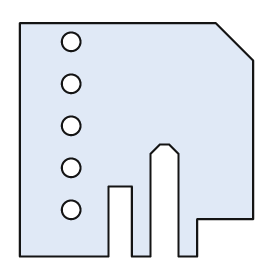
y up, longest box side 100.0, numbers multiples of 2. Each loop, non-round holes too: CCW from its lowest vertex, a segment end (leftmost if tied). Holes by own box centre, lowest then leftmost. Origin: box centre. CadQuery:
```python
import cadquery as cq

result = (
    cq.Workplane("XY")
    .moveTo(-50.0, -50.0)
    .lineTo(-12.0, -50.0)
    .lineTo(-12.0, -20.0)
    .lineTo(-2.0, -20.0)
    .lineTo(-2.0, -50.0)
    .lineTo(6.0, -50.0)
    .lineTo(6.0, -6.0)
    .lineTo(10.0, -2.0)
    .lineTo(14.0, -2.0)
    .lineTo(18.0, -6.0)
    .lineTo(18.0, -50.0)
    .lineTo(26.0, -50.0)
    .lineTo(26.0, -34.0)
    .lineTo(50.0, -34.0)
    .lineTo(50.0, 34.0)
    .lineTo(34.0, 50.0)
    .lineTo(-50.0, 50.0)
    .close()
    .moveTo(-28.0, -30.0)
    .circle(4.0)
    .moveTo(-28.0, -12.0)
    .circle(4.0)
    .moveTo(-28.0, 6.0)
    .circle(4.0)
    .moveTo(-28.0, 24.0)
    .circle(4.0)
    .moveTo(-28.0, 42.0)
    .circle(4.0)
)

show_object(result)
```